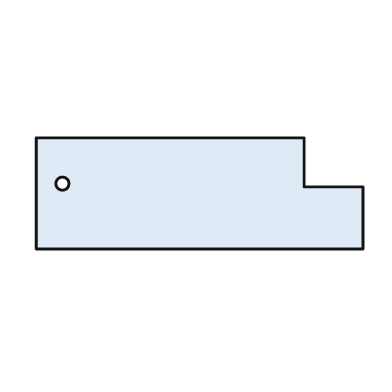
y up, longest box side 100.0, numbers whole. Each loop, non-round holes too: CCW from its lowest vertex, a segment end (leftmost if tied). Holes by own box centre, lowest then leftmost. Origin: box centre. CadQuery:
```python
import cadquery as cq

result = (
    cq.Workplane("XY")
    .moveTo(-50.0, -17.0)
    .lineTo(50.0, -17.0)
    .lineTo(50.0, 2.0)
    .lineTo(32.0, 2.0)
    .lineTo(32.0, 17.0)
    .lineTo(-50.0, 17.0)
    .close()
    .moveTo(-42.0, 3.0)
    .circle(2.0)
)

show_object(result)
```